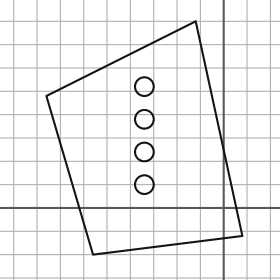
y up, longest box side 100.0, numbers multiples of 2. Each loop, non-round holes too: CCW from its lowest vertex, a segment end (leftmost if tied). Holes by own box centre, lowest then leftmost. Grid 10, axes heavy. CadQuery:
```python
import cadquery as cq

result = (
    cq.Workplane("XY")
    .moveTo(-56.0, -20.0)
    .lineTo(8.0, -12.0)
    .lineTo(-12.0, 80.0)
    .lineTo(-76.0, 48.0)
    .close()
    .moveTo(-34.0, 10.0)
    .circle(4.0)
    .moveTo(-34.0, 24.0)
    .circle(4.0)
    .moveTo(-34.0, 38.0)
    .circle(4.0)
    .moveTo(-34.0, 52.0)
    .circle(4.0)
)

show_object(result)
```